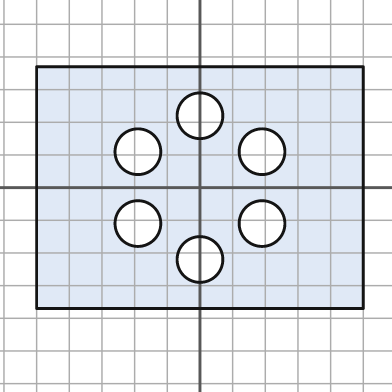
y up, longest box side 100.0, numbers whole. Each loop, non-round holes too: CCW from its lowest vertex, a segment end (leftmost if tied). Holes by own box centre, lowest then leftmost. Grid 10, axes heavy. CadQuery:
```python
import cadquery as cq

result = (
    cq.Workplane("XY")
    .moveTo(-50.0, -37.0)
    .lineTo(50.0, -37.0)
    .lineTo(50.0, 37.0)
    .lineTo(-50.0, 37.0)
    .close()
    .moveTo(0.0, -22.0)
    .circle(7.0)
    .moveTo(-19.0, -11.0)
    .circle(7.0)
    .moveTo(19.0, -11.0)
    .circle(7.0)
    .moveTo(-19.0, 11.0)
    .circle(7.0)
    .moveTo(19.0, 11.0)
    .circle(7.0)
    .moveTo(0.0, 22.0)
    .circle(7.0)
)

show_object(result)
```